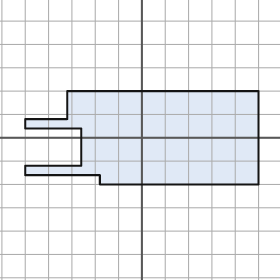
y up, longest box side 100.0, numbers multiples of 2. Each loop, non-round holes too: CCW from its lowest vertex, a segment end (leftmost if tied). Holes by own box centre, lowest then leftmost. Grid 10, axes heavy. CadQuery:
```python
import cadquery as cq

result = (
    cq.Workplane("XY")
    .moveTo(-18.0, -20.0)
    .lineTo(50.0, -20.0)
    .lineTo(50.0, 20.0)
    .lineTo(-32.0, 20.0)
    .lineTo(-32.0, 8.0)
    .lineTo(-50.0, 8.0)
    .lineTo(-50.0, 4.0)
    .lineTo(-26.0, 4.0)
    .lineTo(-26.0, -12.0)
    .lineTo(-50.0, -12.0)
    .lineTo(-50.0, -16.0)
    .lineTo(-18.0, -16.0)
    .close()
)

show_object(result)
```